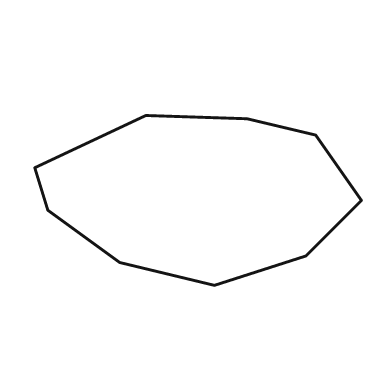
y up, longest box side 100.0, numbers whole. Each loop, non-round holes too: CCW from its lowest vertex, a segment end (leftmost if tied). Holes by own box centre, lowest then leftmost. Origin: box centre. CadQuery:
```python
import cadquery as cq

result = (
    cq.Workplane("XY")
    .moveTo(5.0, -26.0)
    .lineTo(33.0, -17.0)
    .lineTo(50.0, 0.0)
    .lineTo(36.0, 20.0)
    .lineTo(15.0, 25.0)
    .lineTo(-16.0, 26.0)
    .lineTo(-50.0, 10.0)
    .lineTo(-46.0, -3.0)
    .lineTo(-24.0, -19.0)
    .close()
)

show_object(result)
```